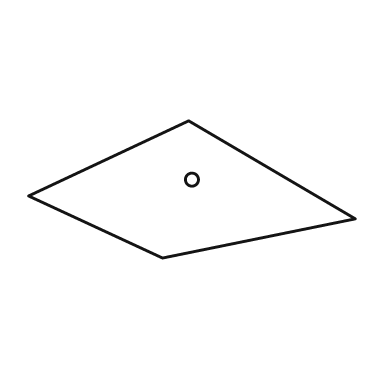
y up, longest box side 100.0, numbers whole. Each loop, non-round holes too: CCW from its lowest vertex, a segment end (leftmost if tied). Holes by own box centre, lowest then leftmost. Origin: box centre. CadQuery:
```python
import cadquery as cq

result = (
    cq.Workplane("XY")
    .moveTo(-9.0, -21.0)
    .lineTo(50.0, -9.0)
    .lineTo(-1.0, 21.0)
    .lineTo(-50.0, -2.0)
    .close()
    .moveTo(0.0, 3.0)
    .circle(2.0)
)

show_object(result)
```